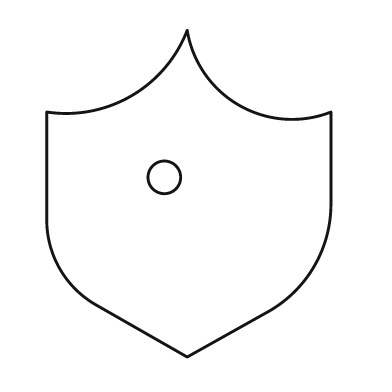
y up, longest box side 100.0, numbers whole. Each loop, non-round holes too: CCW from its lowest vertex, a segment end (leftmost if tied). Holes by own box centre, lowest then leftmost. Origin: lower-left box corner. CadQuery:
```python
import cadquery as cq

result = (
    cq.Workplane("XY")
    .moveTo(43.0, 0.0)
    .lineTo(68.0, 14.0)
    .threePointArc((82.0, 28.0), (87.0, 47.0))
    .lineTo(87.0, 75.0)
    .threePointArc((59.0, 77.0), (43.0, 100.0))
    .threePointArc((26.0, 80.0), (0.0, 75.0))
    .lineTo(0.0, 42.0)
    .threePointArc((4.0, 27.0), (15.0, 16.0))
    .close()
    .moveTo(36.0, 55.0)
    .circle(5.0)
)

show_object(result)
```